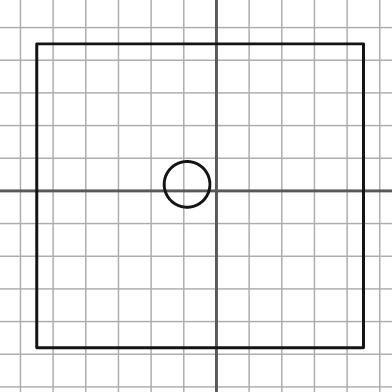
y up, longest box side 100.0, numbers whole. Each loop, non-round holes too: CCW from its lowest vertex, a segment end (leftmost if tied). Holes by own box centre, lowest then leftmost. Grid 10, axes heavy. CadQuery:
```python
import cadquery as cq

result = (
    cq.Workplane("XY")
    .moveTo(-55.0, -48.0)
    .lineTo(45.0, -48.0)
    .lineTo(45.0, 45.0)
    .lineTo(-55.0, 45.0)
    .close()
    .moveTo(-9.0, 2.0)
    .circle(7.0)
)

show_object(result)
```